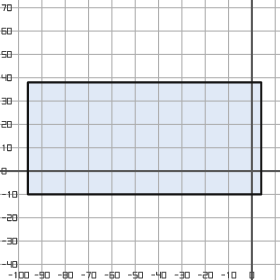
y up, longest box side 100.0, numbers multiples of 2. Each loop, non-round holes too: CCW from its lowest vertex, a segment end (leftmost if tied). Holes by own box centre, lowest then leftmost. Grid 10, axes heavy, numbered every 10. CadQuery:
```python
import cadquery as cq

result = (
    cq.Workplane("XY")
    .moveTo(-96.0, -10.0)
    .lineTo(4.0, -10.0)
    .lineTo(4.0, 38.0)
    .lineTo(-96.0, 38.0)
    .close()
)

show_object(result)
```